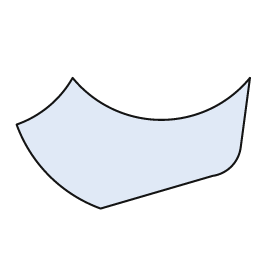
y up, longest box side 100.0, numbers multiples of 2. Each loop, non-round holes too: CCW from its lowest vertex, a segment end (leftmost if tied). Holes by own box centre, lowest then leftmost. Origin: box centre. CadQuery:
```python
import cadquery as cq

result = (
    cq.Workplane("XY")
    .moveTo(-14.0, -28.0)
    .lineTo(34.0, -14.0)
    .threePointArc((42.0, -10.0), (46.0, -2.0))
    .lineTo(50.0, 28.0)
    .threePointArc((12.0, 10.0), (-26.0, 28.0))
    .threePointArc((-36.0, 16.0), (-50.0, 8.0))
    .threePointArc((-36.0, -14.0), (-14.0, -28.0))
    .close()
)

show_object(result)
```